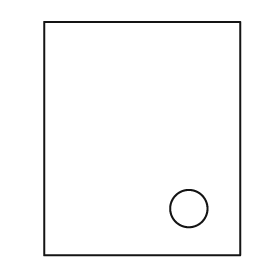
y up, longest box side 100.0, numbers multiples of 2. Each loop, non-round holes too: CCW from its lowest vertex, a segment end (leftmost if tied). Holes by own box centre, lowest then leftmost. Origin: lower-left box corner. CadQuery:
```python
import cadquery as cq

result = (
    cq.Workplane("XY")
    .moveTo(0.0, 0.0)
    .lineTo(84.0, 0.0)
    .lineTo(84.0, 100.0)
    .lineTo(0.0, 100.0)
    .close()
    .moveTo(62.0, 20.0)
    .circle(8.0)
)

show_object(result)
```